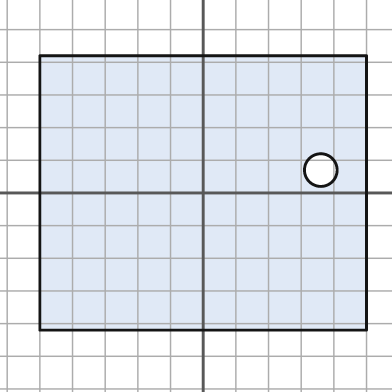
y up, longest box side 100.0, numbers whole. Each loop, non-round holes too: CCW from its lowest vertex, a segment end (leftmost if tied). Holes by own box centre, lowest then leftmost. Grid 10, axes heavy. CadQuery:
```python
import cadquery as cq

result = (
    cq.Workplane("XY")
    .moveTo(-50.0, -42.0)
    .lineTo(50.0, -42.0)
    .lineTo(50.0, 42.0)
    .lineTo(-50.0, 42.0)
    .close()
    .moveTo(36.0, 7.0)
    .circle(5.0)
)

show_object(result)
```